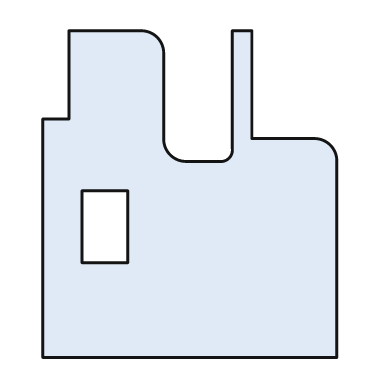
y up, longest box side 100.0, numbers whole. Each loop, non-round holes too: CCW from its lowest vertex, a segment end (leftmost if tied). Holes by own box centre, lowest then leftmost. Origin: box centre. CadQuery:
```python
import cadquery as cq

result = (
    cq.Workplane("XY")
    .moveTo(-45.0, -50.0)
    .lineTo(45.0, -50.0)
    .lineTo(45.0, 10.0)
    .threePointArc((43.0, 15.0), (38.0, 17.0))
    .lineTo(19.0, 17.0)
    .lineTo(19.0, 50.0)
    .lineTo(13.0, 50.0)
    .lineTo(13.0, 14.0)
    .threePointArc((12.0, 11.0), (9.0, 10.0))
    .lineTo(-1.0, 10.0)
    .threePointArc((-6.0, 12.0), (-8.0, 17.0))
    .lineTo(-8.0, 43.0)
    .threePointArc((-10.0, 48.0), (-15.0, 50.0))
    .lineTo(-37.0, 50.0)
    .lineTo(-37.0, 23.0)
    .lineTo(-45.0, 23.0)
    .close()
    .moveTo(-33.0, -21.0)
    .lineTo(-19.0, -21.0)
    .lineTo(-19.0, 1.0)
    .lineTo(-33.0, 1.0)
    .close()
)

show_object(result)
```